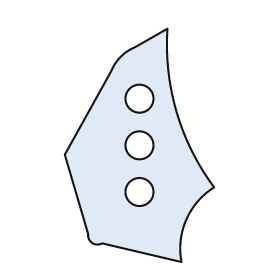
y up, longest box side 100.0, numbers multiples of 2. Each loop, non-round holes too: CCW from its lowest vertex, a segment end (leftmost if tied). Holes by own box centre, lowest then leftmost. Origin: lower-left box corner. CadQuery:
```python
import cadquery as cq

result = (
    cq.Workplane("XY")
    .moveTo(50.0, 0.0)
    .threePointArc((52.0, 18.0), (64.0, 32.0))
    .threePointArc((48.0, 64.0), (44.0, 100.0))
    .lineTo(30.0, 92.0)
    .threePointArc((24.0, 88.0), (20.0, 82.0))
    .lineTo(0.0, 46.0)
    .lineTo(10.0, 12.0)
    .threePointArc((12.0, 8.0), (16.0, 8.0))
    .close()
    .moveTo(32.0, 30.0)
    .circle(6.0)
    .moveTo(32.0, 50.0)
    .circle(6.0)
    .moveTo(32.0, 70.0)
    .circle(6.0)
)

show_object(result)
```